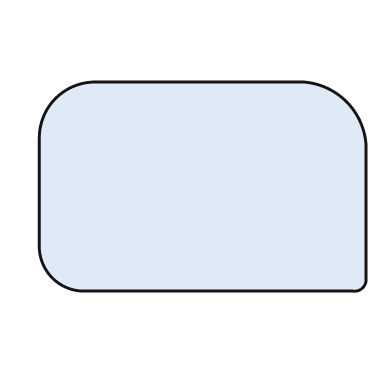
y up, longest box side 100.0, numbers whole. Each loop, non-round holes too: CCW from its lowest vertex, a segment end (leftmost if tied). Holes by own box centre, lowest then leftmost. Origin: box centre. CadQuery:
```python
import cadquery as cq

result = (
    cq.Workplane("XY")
    .moveTo(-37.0, -32.0)
    .lineTo(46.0, -32.0)
    .threePointArc((49.0, -31.0), (50.0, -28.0))
    .lineTo(50.0, 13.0)
    .threePointArc((44.0, 26.0), (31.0, 32.0))
    .lineTo(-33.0, 32.0)
    .threePointArc((-45.0, 27.0), (-50.0, 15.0))
    .lineTo(-50.0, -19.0)
    .threePointArc((-46.0, -28.0), (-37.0, -32.0))
    .close()
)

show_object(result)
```